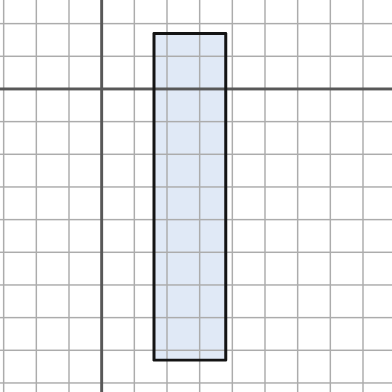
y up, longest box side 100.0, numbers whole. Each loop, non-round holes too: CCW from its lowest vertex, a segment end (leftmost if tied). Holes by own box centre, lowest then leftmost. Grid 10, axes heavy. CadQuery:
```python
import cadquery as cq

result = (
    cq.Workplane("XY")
    .moveTo(16.0, -83.0)
    .lineTo(38.0, -83.0)
    .lineTo(38.0, 17.0)
    .lineTo(16.0, 17.0)
    .close()
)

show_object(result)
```